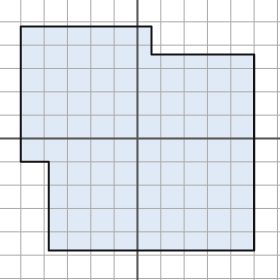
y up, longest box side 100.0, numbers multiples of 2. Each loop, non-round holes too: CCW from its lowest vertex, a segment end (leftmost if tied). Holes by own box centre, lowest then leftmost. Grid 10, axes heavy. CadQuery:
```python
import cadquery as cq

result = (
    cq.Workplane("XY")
    .moveTo(-38.0, -48.0)
    .lineTo(50.0, -48.0)
    .lineTo(50.0, 36.0)
    .lineTo(6.0, 36.0)
    .lineTo(6.0, 48.0)
    .lineTo(-50.0, 48.0)
    .lineTo(-50.0, -10.0)
    .lineTo(-38.0, -10.0)
    .close()
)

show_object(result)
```